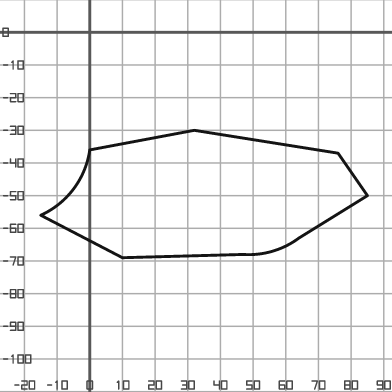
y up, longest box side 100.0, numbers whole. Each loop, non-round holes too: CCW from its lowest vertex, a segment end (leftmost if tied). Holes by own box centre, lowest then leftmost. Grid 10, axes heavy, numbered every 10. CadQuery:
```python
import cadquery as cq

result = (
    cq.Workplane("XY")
    .moveTo(10.0, -69.0)
    .lineTo(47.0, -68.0)
    .threePointArc((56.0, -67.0), (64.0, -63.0))
    .lineTo(85.0, -50.0)
    .lineTo(76.0, -37.0)
    .lineTo(32.0, -30.0)
    .lineTo(0.0, -36.0)
    .threePointArc((-5.0, -48.0), (-15.0, -56.0))
    .close()
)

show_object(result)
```